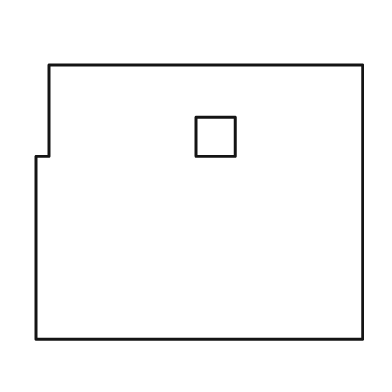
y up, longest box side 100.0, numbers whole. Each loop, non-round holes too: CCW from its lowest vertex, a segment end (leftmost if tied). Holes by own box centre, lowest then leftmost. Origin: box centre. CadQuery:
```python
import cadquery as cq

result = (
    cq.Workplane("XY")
    .moveTo(-50.0, -42.0)
    .lineTo(50.0, -42.0)
    .lineTo(50.0, 42.0)
    .lineTo(-46.0, 42.0)
    .lineTo(-46.0, 14.0)
    .lineTo(-50.0, 14.0)
    .close()
    .moveTo(-1.0, 14.0)
    .lineTo(11.0, 14.0)
    .lineTo(11.0, 26.0)
    .lineTo(-1.0, 26.0)
    .close()
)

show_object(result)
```